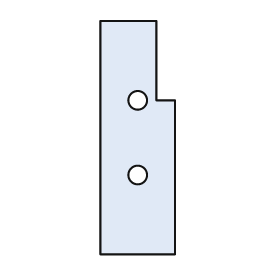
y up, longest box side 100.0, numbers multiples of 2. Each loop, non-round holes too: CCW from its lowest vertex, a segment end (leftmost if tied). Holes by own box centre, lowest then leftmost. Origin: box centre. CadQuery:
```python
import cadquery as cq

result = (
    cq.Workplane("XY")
    .moveTo(-16.0, -50.0)
    .lineTo(16.0, -50.0)
    .lineTo(16.0, 16.0)
    .lineTo(8.0, 16.0)
    .lineTo(8.0, 50.0)
    .lineTo(-16.0, 50.0)
    .close()
    .moveTo(0.0, -16.0)
    .circle(4.0)
    .moveTo(0.0, 16.0)
    .circle(4.0)
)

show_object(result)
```